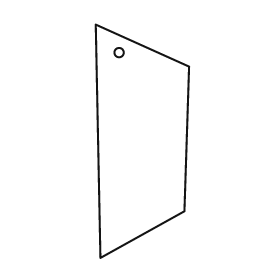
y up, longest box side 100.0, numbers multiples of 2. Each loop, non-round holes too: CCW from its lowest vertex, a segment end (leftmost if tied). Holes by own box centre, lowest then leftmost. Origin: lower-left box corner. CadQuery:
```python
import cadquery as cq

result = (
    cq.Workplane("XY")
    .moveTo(2.0, 0.0)
    .lineTo(38.0, 20.0)
    .lineTo(40.0, 82.0)
    .lineTo(0.0, 100.0)
    .close()
    .moveTo(10.0, 88.0)
    .circle(2.0)
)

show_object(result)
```